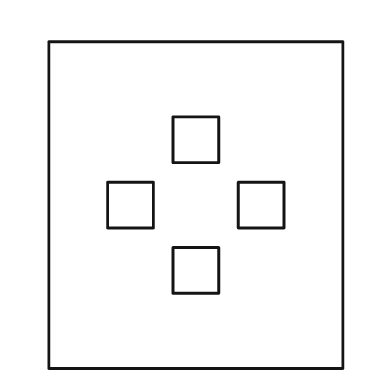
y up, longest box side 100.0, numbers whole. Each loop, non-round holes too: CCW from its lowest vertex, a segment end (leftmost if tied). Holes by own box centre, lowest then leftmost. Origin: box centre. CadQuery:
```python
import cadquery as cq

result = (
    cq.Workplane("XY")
    .moveTo(-45.0, -50.0)
    .lineTo(45.0, -50.0)
    .lineTo(45.0, 50.0)
    .lineTo(-45.0, 50.0)
    .close()
    .moveTo(-7.0, -27.0)
    .lineTo(7.0, -27.0)
    .lineTo(7.0, -13.0)
    .lineTo(-7.0, -13.0)
    .close()
    .moveTo(-27.0, -7.0)
    .lineTo(-13.0, -7.0)
    .lineTo(-13.0, 7.0)
    .lineTo(-27.0, 7.0)
    .close()
    .moveTo(13.0, -7.0)
    .lineTo(27.0, -7.0)
    .lineTo(27.0, 7.0)
    .lineTo(13.0, 7.0)
    .close()
    .moveTo(-7.0, 13.0)
    .lineTo(7.0, 13.0)
    .lineTo(7.0, 27.0)
    .lineTo(-7.0, 27.0)
    .close()
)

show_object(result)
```